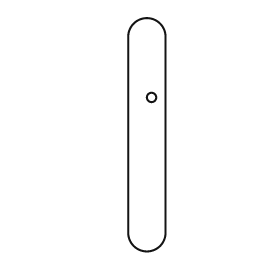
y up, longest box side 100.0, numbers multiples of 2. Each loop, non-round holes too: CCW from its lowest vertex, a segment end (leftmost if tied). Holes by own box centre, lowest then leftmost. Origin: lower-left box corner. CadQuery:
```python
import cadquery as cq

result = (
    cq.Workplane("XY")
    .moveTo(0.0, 8.0)
    .threePointArc((8.0, 0.0), (16.0, 8.0))
    .lineTo(16.0, 92.0)
    .threePointArc((8.0, 100.0), (0.0, 92.0))
    .close()
    .moveTo(10.0, 66.0)
    .circle(2.0)
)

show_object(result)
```